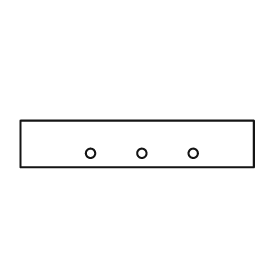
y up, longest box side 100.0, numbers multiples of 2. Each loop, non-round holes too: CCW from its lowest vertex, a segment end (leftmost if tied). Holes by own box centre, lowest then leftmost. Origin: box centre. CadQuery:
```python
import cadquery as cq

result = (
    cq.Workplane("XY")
    .moveTo(-50.0, -10.0)
    .lineTo(50.0, -10.0)
    .lineTo(50.0, 10.0)
    .lineTo(-50.0, 10.0)
    .close()
    .moveTo(-20.0, -4.0)
    .circle(2.0)
    .moveTo(2.0, -4.0)
    .circle(2.0)
    .moveTo(24.0, -4.0)
    .circle(2.0)
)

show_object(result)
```